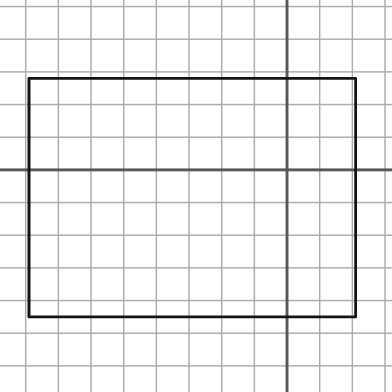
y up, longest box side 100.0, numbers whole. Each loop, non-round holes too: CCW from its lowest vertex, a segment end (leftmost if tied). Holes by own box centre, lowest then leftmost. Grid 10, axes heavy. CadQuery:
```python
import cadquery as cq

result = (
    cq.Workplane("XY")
    .moveTo(-79.0, -45.0)
    .lineTo(21.0, -45.0)
    .lineTo(21.0, 28.0)
    .lineTo(-79.0, 28.0)
    .close()
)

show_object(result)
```